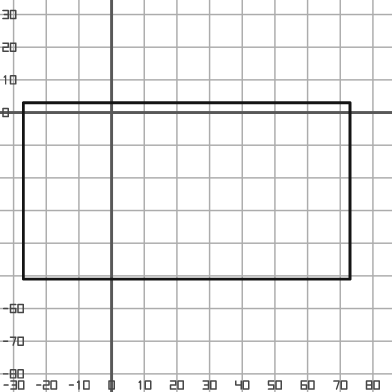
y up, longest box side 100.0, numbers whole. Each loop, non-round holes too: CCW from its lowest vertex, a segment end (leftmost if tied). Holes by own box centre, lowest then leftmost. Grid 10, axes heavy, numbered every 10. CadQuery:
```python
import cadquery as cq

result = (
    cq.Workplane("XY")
    .moveTo(-27.0, -51.0)
    .lineTo(73.0, -51.0)
    .lineTo(73.0, 3.0)
    .lineTo(-27.0, 3.0)
    .close()
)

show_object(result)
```